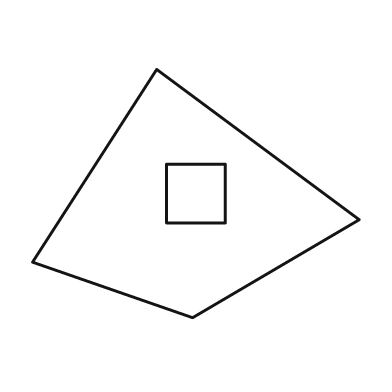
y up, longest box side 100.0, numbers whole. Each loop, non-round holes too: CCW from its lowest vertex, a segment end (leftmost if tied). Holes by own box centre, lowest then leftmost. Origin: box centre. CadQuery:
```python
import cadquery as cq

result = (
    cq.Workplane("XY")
    .moveTo(-1.0, -38.0)
    .lineTo(50.0, -8.0)
    .lineTo(-12.0, 38.0)
    .lineTo(-50.0, -21.0)
    .close()
    .moveTo(-9.0, -9.0)
    .lineTo(9.0, -9.0)
    .lineTo(9.0, 9.0)
    .lineTo(-9.0, 9.0)
    .close()
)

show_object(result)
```